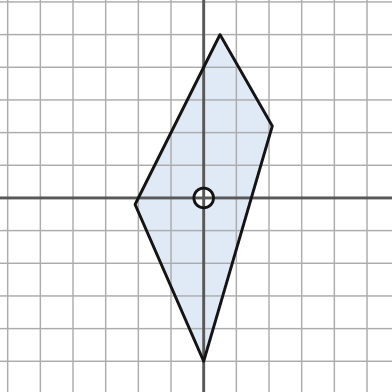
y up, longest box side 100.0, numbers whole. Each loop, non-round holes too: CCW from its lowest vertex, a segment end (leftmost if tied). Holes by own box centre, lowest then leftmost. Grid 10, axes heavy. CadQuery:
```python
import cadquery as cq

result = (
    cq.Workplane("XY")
    .moveTo(0.0, -50.0)
    .lineTo(21.0, 22.0)
    .lineTo(5.0, 50.0)
    .lineTo(-21.0, -2.0)
    .close()
    .moveTo(0.0, 0.0)
    .circle(3.0)
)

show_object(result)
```